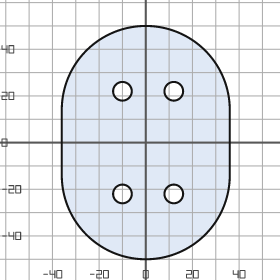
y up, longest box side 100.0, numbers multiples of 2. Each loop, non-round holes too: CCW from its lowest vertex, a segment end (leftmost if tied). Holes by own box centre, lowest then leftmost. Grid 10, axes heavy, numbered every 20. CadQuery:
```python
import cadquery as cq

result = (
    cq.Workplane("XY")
    .moveTo(-36.0, -14.0)
    .threePointArc((0.0, -50.0), (36.0, -14.0))
    .lineTo(36.0, 14.0)
    .threePointArc((0.0, 50.0), (-36.0, 14.0))
    .close()
    .moveTo(-10.0, -22.0)
    .circle(4.0)
    .moveTo(12.0, -22.0)
    .circle(4.0)
    .moveTo(-10.0, 22.0)
    .circle(4.0)
    .moveTo(12.0, 22.0)
    .circle(4.0)
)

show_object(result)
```